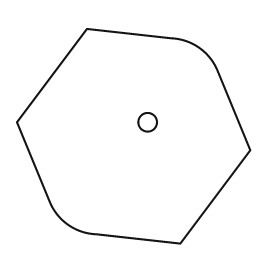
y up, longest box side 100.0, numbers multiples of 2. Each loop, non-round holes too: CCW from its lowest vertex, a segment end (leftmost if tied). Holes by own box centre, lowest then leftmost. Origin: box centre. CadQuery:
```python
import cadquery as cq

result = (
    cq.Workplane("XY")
    .moveTo(20.0, -46.0)
    .lineTo(50.0, -6.0)
    .lineTo(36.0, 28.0)
    .threePointArc((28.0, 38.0), (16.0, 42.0))
    .lineTo(-20.0, 46.0)
    .lineTo(-50.0, 6.0)
    .lineTo(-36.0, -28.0)
    .threePointArc((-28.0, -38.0), (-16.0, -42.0))
    .close()
    .moveTo(6.0, 6.0)
    .circle(4.0)
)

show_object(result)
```